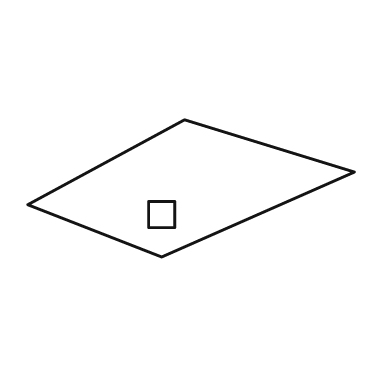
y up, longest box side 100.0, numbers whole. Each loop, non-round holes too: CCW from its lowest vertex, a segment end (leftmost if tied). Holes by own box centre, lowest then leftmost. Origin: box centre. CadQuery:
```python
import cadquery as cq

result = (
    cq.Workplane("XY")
    .moveTo(-9.0, -21.0)
    .lineTo(50.0, 5.0)
    .lineTo(-2.0, 21.0)
    .lineTo(-50.0, -5.0)
    .close()
    .moveTo(-13.0, -12.0)
    .lineTo(-5.0, -12.0)
    .lineTo(-5.0, -4.0)
    .lineTo(-13.0, -4.0)
    .close()
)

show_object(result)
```